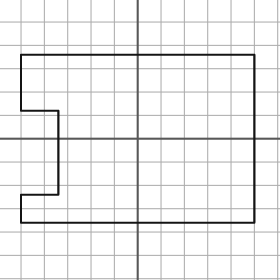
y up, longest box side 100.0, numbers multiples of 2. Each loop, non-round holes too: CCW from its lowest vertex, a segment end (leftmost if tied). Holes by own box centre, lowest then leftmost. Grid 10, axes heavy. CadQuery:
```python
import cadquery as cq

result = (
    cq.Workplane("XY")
    .moveTo(-50.0, -36.0)
    .lineTo(50.0, -36.0)
    .lineTo(50.0, 36.0)
    .lineTo(-50.0, 36.0)
    .lineTo(-50.0, 12.0)
    .lineTo(-34.0, 12.0)
    .lineTo(-34.0, -24.0)
    .lineTo(-50.0, -24.0)
    .close()
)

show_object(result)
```